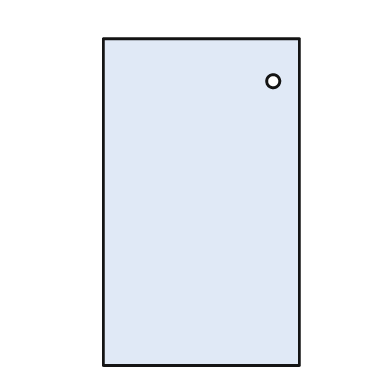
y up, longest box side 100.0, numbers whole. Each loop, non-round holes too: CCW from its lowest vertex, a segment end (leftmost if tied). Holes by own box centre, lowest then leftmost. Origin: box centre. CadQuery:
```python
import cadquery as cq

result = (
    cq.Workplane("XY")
    .moveTo(-30.0, -50.0)
    .lineTo(30.0, -50.0)
    .lineTo(30.0, 50.0)
    .lineTo(-30.0, 50.0)
    .close()
    .moveTo(22.0, 37.0)
    .circle(2.0)
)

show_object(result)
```